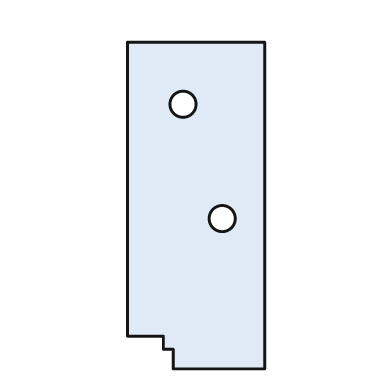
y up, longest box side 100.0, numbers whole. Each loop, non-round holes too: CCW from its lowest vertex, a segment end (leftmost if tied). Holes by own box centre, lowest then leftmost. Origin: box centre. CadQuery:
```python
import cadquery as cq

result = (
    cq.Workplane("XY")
    .moveTo(-7.0, -50.0)
    .lineTo(21.0, -50.0)
    .lineTo(21.0, 50.0)
    .lineTo(-21.0, 50.0)
    .lineTo(-21.0, -40.0)
    .lineTo(-10.0, -40.0)
    .lineTo(-10.0, -44.0)
    .lineTo(-7.0, -44.0)
    .close()
    .moveTo(8.0, -4.0)
    .circle(4.0)
    .moveTo(-4.0, 31.0)
    .circle(4.0)
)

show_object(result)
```